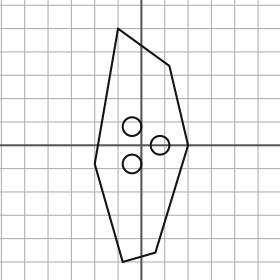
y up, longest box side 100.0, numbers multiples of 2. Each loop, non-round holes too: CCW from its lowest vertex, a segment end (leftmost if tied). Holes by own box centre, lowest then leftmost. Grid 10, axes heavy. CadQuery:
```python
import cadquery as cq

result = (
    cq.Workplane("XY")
    .moveTo(-8.0, -50.0)
    .lineTo(6.0, -46.0)
    .lineTo(20.0, 0.0)
    .lineTo(12.0, 34.0)
    .lineTo(-10.0, 50.0)
    .lineTo(-20.0, -8.0)
    .close()
    .moveTo(-4.0, -8.0)
    .circle(4.0)
    .moveTo(8.0, 0.0)
    .circle(4.0)
    .moveTo(-4.0, 8.0)
    .circle(4.0)
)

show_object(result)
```